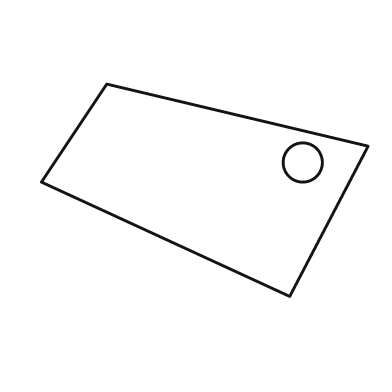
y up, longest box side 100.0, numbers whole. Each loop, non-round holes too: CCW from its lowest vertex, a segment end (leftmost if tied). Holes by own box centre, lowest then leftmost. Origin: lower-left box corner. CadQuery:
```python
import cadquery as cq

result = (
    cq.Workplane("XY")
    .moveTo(76.0, 0.0)
    .lineTo(100.0, 46.0)
    .lineTo(20.0, 65.0)
    .lineTo(0.0, 35.0)
    .close()
    .moveTo(80.0, 41.0)
    .circle(6.0)
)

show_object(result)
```